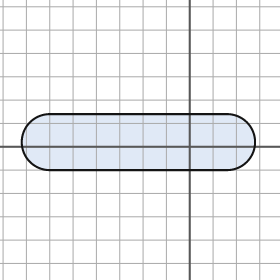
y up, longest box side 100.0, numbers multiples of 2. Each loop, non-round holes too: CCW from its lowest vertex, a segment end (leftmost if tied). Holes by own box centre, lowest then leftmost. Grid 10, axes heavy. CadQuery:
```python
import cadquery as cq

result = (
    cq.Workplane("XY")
    .moveTo(-60.0, -10.0)
    .lineTo(16.0, -10.0)
    .threePointArc((28.0, 2.0), (16.0, 14.0))
    .lineTo(-60.0, 14.0)
    .threePointArc((-72.0, 2.0), (-60.0, -10.0))
    .close()
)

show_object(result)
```